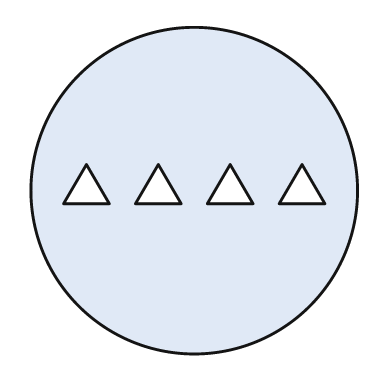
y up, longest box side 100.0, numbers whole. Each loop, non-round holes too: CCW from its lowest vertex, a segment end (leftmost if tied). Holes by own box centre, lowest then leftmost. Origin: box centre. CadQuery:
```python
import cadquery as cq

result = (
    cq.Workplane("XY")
    .moveTo(0.0, 0.0)
    .circle(50.0)
    .moveTo(-40.0, -4.0)
    .lineTo(-26.0, -4.0)
    .lineTo(-33.0, 8.0)
    .close()
    .moveTo(-18.0, -4.0)
    .lineTo(-4.0, -4.0)
    .lineTo(-11.0, 8.0)
    .close()
    .moveTo(4.0, -4.0)
    .lineTo(18.0, -4.0)
    .lineTo(11.0, 8.0)
    .close()
    .moveTo(26.0, -4.0)
    .lineTo(40.0, -4.0)
    .lineTo(33.0, 8.0)
    .close()
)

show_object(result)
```